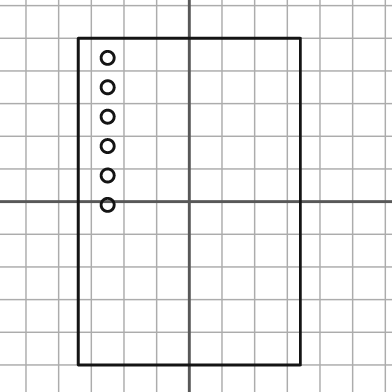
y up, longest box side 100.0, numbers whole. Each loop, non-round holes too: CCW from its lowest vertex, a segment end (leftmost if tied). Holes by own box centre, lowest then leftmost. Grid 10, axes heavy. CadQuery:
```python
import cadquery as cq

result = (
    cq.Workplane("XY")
    .moveTo(-34.0, -50.0)
    .lineTo(34.0, -50.0)
    .lineTo(34.0, 50.0)
    .lineTo(-34.0, 50.0)
    .close()
    .moveTo(-25.0, -1.0)
    .circle(2.0)
    .moveTo(-25.0, 8.0)
    .circle(2.0)
    .moveTo(-25.0, 17.0)
    .circle(2.0)
    .moveTo(-25.0, 26.0)
    .circle(2.0)
    .moveTo(-25.0, 35.0)
    .circle(2.0)
    .moveTo(-25.0, 44.0)
    .circle(2.0)
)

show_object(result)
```